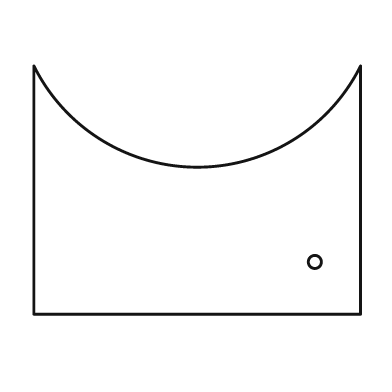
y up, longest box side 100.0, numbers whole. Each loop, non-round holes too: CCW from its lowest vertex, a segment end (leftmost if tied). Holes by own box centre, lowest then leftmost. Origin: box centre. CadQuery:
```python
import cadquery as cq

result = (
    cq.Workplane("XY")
    .moveTo(-50.0, -38.0)
    .lineTo(50.0, -38.0)
    .lineTo(50.0, 38.0)
    .threePointArc((0.0, 7.0), (-50.0, 38.0))
    .close()
    .moveTo(36.0, -22.0)
    .circle(2.0)
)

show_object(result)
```